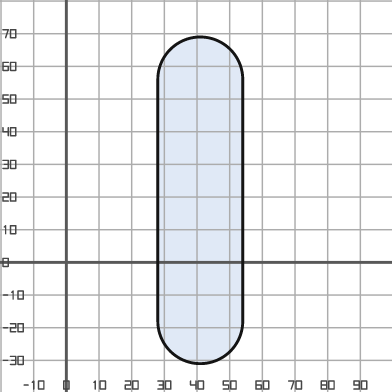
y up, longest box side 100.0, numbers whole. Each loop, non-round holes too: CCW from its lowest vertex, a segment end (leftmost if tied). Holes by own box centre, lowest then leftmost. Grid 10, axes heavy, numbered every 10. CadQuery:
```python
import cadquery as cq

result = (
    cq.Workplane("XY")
    .moveTo(28.0, -18.0)
    .threePointArc((41.0, -31.0), (54.0, -18.0))
    .lineTo(54.0, 56.0)
    .threePointArc((41.0, 69.0), (28.0, 56.0))
    .close()
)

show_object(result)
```